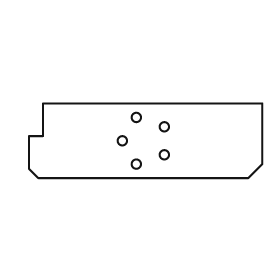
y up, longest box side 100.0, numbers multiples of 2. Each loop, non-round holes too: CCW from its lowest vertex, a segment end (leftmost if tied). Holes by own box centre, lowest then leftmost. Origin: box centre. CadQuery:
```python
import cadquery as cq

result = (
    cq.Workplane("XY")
    .moveTo(-46.0, -16.0)
    .lineTo(44.0, -16.0)
    .lineTo(50.0, -10.0)
    .lineTo(50.0, 16.0)
    .lineTo(-44.0, 16.0)
    .lineTo(-44.0, 2.0)
    .lineTo(-50.0, 2.0)
    .lineTo(-50.0, -12.0)
    .close()
    .moveTo(-4.0, -10.0)
    .circle(2.0)
    .moveTo(8.0, -6.0)
    .circle(2.0)
    .moveTo(-10.0, 0.0)
    .circle(2.0)
    .moveTo(8.0, 6.0)
    .circle(2.0)
    .moveTo(-4.0, 10.0)
    .circle(2.0)
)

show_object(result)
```